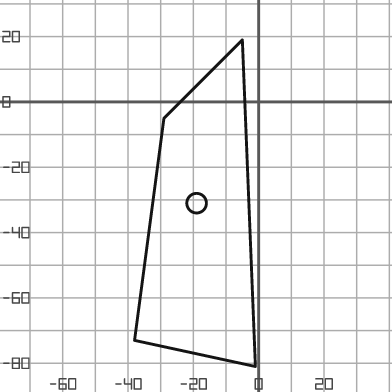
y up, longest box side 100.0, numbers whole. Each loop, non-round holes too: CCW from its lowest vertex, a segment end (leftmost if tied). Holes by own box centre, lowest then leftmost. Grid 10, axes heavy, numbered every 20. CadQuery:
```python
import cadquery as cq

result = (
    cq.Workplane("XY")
    .moveTo(-1.0, -81.0)
    .lineTo(-5.0, 19.0)
    .lineTo(-29.0, -5.0)
    .lineTo(-38.0, -73.0)
    .close()
    .moveTo(-19.0, -31.0)
    .circle(3.0)
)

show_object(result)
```